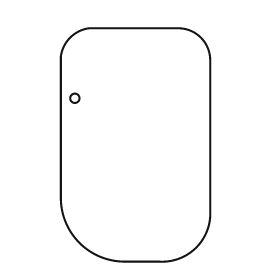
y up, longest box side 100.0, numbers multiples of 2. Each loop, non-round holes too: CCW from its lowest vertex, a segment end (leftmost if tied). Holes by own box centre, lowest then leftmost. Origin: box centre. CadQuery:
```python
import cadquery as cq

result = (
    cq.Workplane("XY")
    .moveTo(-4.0, -50.0)
    .lineTo(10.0, -50.0)
    .threePointArc((26.0, -44.0), (32.0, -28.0))
    .lineTo(32.0, 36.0)
    .threePointArc((28.0, 46.0), (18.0, 50.0))
    .lineTo(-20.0, 50.0)
    .threePointArc((-28.0, 46.0), (-32.0, 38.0))
    .lineTo(-32.0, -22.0)
    .threePointArc((-24.0, -42.0), (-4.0, -50.0))
    .close()
    .moveTo(-26.0, 20.0)
    .circle(2.0)
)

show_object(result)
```